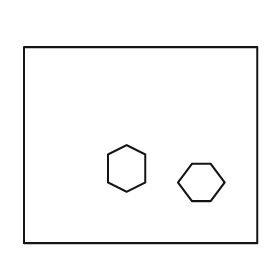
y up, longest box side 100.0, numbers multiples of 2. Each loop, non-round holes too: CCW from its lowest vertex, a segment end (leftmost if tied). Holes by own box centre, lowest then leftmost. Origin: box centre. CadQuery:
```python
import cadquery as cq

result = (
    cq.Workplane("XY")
    .moveTo(-50.0, -42.0)
    .lineTo(50.0, -42.0)
    .lineTo(50.0, 42.0)
    .lineTo(-50.0, 42.0)
    .close()
    .moveTo(22.0, -24.0)
    .lineTo(30.0, -24.0)
    .lineTo(36.0, -16.0)
    .lineTo(30.0, -8.0)
    .lineTo(22.0, -8.0)
    .lineTo(16.0, -16.0)
    .close()
    .moveTo(-6.0, -20.0)
    .lineTo(2.0, -16.0)
    .lineTo(2.0, -4.0)
    .lineTo(-6.0, 0.0)
    .lineTo(-14.0, -4.0)
    .lineTo(-14.0, -16.0)
    .close()
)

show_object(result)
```